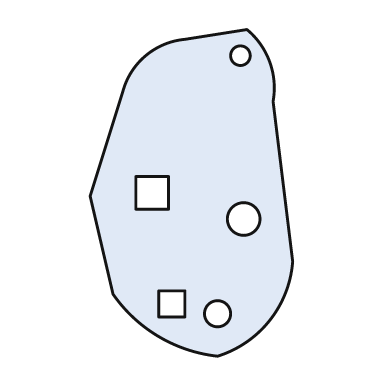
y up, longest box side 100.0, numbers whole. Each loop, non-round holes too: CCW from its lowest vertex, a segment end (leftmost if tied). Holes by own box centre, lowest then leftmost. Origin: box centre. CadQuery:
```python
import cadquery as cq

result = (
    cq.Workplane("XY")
    .moveTo(8.0, -50.0)
    .threePointArc((24.0, -39.0), (31.0, -21.0))
    .lineTo(25.0, 28.0)
    .threePointArc((24.0, 40.0), (17.0, 50.0))
    .lineTo(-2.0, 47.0)
    .threePointArc((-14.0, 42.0), (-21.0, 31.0))
    .lineTo(-31.0, -1.0)
    .lineTo(-24.0, -31.0)
    .threePointArc((-10.0, -44.0), (8.0, -50.0))
    .close()
    .moveTo(8.0, -37.0)
    .circle(4.0)
    .moveTo(-10.0, -38.0)
    .lineTo(-2.0, -38.0)
    .lineTo(-2.0, -30.0)
    .lineTo(-10.0, -30.0)
    .close()
    .moveTo(16.0, -8.0)
    .circle(5.0)
    .moveTo(-17.0, -5.0)
    .lineTo(-7.0, -5.0)
    .lineTo(-7.0, 5.0)
    .lineTo(-17.0, 5.0)
    .close()
    .moveTo(15.0, 42.0)
    .circle(3.0)
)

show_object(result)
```